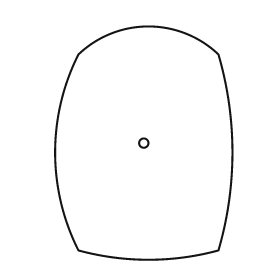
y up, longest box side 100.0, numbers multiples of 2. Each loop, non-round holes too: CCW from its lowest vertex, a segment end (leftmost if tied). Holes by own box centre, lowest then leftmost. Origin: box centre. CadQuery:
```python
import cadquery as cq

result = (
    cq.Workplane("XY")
    .moveTo(-28.0, -46.0)
    .threePointArc((2.0, -50.0), (32.0, -46.0))
    .threePointArc((38.0, -4.0), (32.0, 38.0))
    .threePointArc((2.0, 50.0), (-28.0, 38.0))
    .threePointArc((-38.0, -4.0), (-28.0, -46.0))
    .close()
    .moveTo(0.0, 0.0)
    .circle(2.0)
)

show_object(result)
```